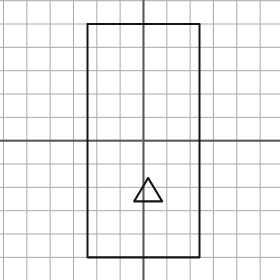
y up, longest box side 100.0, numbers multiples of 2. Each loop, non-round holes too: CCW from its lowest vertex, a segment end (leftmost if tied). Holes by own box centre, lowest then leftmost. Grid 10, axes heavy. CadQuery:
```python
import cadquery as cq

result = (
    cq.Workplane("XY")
    .moveTo(-24.0, -50.0)
    .lineTo(24.0, -50.0)
    .lineTo(24.0, 50.0)
    .lineTo(-24.0, 50.0)
    .close()
    .moveTo(-4.0, -26.0)
    .lineTo(8.0, -26.0)
    .lineTo(2.0, -16.0)
    .close()
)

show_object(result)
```